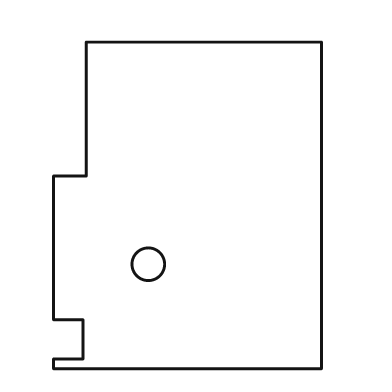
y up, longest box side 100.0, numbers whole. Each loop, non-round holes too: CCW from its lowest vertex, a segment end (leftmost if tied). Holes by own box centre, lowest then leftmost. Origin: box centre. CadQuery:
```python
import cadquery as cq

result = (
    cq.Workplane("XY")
    .moveTo(-41.0, -50.0)
    .lineTo(41.0, -50.0)
    .lineTo(41.0, 50.0)
    .lineTo(-31.0, 50.0)
    .lineTo(-31.0, 9.0)
    .lineTo(-41.0, 9.0)
    .lineTo(-41.0, -35.0)
    .lineTo(-32.0, -35.0)
    .lineTo(-32.0, -47.0)
    .lineTo(-41.0, -47.0)
    .close()
    .moveTo(-12.0, -18.0)
    .circle(5.0)
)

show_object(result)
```